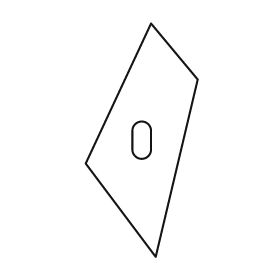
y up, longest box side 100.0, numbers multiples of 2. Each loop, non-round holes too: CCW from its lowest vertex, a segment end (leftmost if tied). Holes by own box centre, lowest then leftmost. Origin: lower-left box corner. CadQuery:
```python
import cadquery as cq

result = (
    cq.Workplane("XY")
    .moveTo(30.0, 0.0)
    .lineTo(48.0, 76.0)
    .lineTo(28.0, 100.0)
    .lineTo(0.0, 40.0)
    .close()
    .moveTo(20.0, 46.0)
    .threePointArc((24.0, 42.0), (28.0, 46.0))
    .lineTo(28.0, 54.0)
    .threePointArc((24.0, 58.0), (20.0, 54.0))
    .close()
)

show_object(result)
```